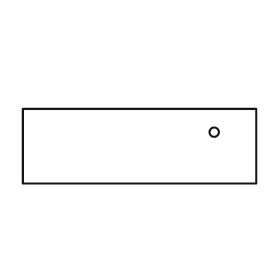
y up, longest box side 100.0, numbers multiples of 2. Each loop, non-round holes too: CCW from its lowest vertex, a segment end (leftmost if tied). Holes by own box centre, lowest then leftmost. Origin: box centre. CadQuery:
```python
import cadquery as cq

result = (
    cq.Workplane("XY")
    .moveTo(-50.0, -16.0)
    .lineTo(50.0, -16.0)
    .lineTo(50.0, 16.0)
    .lineTo(-50.0, 16.0)
    .close()
    .moveTo(32.0, 6.0)
    .circle(2.0)
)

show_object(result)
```